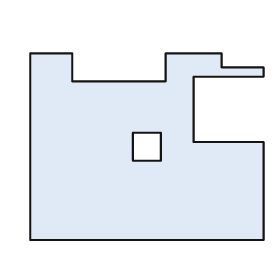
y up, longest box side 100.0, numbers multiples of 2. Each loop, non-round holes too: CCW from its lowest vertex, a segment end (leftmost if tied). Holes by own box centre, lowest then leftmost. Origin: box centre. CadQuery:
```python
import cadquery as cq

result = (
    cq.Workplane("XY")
    .moveTo(-50.0, -40.0)
    .lineTo(50.0, -40.0)
    .lineTo(50.0, 2.0)
    .lineTo(20.0, 2.0)
    .lineTo(20.0, 30.0)
    .lineTo(50.0, 30.0)
    .lineTo(50.0, 34.0)
    .lineTo(32.0, 34.0)
    .lineTo(32.0, 40.0)
    .lineTo(8.0, 40.0)
    .lineTo(8.0, 28.0)
    .lineTo(-32.0, 28.0)
    .lineTo(-32.0, 40.0)
    .lineTo(-50.0, 40.0)
    .close()
    .moveTo(-6.0, -6.0)
    .lineTo(6.0, -6.0)
    .lineTo(6.0, 6.0)
    .lineTo(-6.0, 6.0)
    .close()
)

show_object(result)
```